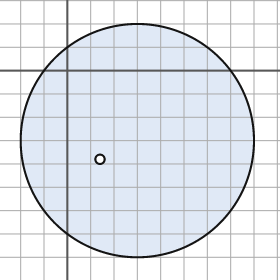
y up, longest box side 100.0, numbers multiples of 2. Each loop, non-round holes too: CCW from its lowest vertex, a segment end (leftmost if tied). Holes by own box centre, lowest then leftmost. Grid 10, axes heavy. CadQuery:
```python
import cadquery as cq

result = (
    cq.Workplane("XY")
    .moveTo(30.0, -30.0)
    .circle(50.0)
    .moveTo(14.0, -38.0)
    .circle(2.0)
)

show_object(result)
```